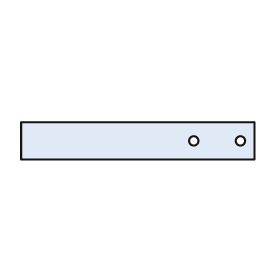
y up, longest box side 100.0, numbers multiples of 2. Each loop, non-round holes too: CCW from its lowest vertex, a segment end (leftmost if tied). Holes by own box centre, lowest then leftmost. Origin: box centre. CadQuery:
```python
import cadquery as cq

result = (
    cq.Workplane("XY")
    .moveTo(-50.0, -8.0)
    .lineTo(50.0, -8.0)
    .lineTo(50.0, 8.0)
    .lineTo(-50.0, 8.0)
    .close()
    .moveTo(24.0, 0.0)
    .circle(2.0)
    .moveTo(44.0, 0.0)
    .circle(2.0)
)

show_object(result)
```